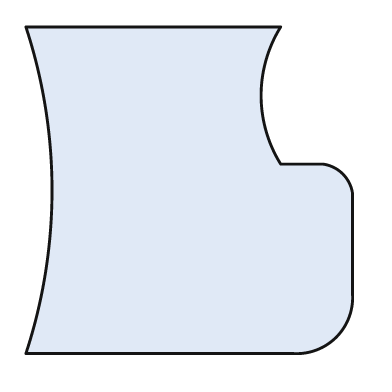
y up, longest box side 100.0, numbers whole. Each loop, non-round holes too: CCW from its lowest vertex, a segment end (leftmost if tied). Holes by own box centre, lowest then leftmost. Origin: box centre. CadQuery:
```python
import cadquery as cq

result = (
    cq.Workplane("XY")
    .moveTo(-50.0, -50.0)
    .lineTo(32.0, -50.0)
    .threePointArc((45.0, -45.0), (50.0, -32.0))
    .lineTo(50.0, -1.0)
    .threePointArc((47.0, 5.0), (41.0, 8.0))
    .lineTo(28.0, 8.0)
    .threePointArc((22.0, 29.0), (28.0, 50.0))
    .lineTo(-50.0, 50.0)
    .threePointArc((-42.0, 0.0), (-50.0, -50.0))
    .close()
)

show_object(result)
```